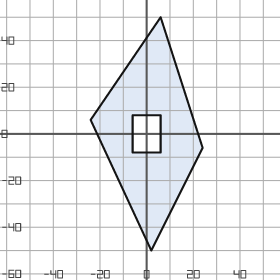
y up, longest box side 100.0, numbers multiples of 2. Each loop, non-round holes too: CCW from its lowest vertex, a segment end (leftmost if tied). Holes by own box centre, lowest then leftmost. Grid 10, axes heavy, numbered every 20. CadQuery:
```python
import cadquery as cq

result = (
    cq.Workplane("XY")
    .moveTo(2.0, -50.0)
    .lineTo(24.0, -6.0)
    .lineTo(6.0, 50.0)
    .lineTo(-24.0, 6.0)
    .close()
    .moveTo(-6.0, -8.0)
    .lineTo(6.0, -8.0)
    .lineTo(6.0, 8.0)
    .lineTo(-6.0, 8.0)
    .close()
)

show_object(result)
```